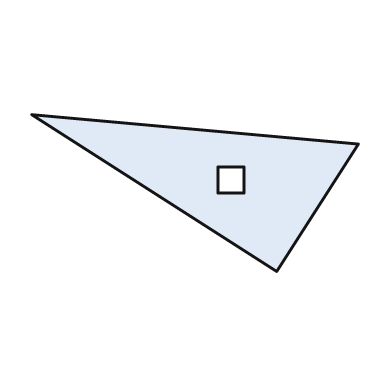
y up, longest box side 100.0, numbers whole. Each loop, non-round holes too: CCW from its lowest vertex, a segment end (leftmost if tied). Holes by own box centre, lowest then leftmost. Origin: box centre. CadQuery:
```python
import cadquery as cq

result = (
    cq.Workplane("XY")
    .moveTo(25.0, -24.0)
    .lineTo(50.0, 15.0)
    .lineTo(-50.0, 24.0)
    .close()
    .moveTo(7.0, 0.0)
    .lineTo(15.0, 0.0)
    .lineTo(15.0, 8.0)
    .lineTo(7.0, 8.0)
    .close()
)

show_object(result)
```